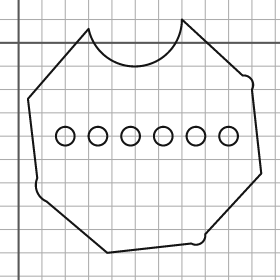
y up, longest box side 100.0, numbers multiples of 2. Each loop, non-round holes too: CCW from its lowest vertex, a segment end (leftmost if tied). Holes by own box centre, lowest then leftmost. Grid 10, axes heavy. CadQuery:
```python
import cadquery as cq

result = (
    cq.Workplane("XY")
    .moveTo(38.0, -90.0)
    .lineTo(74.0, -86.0)
    .threePointArc((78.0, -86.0), (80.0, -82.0))
    .lineTo(104.0, -56.0)
    .lineTo(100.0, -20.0)
    .threePointArc((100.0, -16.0), (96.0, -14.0))
    .lineTo(70.0, 10.0)
    .threePointArc((52.0, -10.0), (30.0, 6.0))
    .lineTo(4.0, -24.0)
    .lineTo(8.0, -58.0)
    .threePointArc((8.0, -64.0), (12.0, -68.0))
    .close()
    .moveTo(20.0, -40.0)
    .circle(4.0)
    .moveTo(34.0, -40.0)
    .circle(4.0)
    .moveTo(48.0, -40.0)
    .circle(4.0)
    .moveTo(62.0, -40.0)
    .circle(4.0)
    .moveTo(76.0, -40.0)
    .circle(4.0)
    .moveTo(90.0, -40.0)
    .circle(4.0)
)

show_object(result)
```